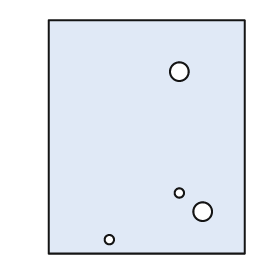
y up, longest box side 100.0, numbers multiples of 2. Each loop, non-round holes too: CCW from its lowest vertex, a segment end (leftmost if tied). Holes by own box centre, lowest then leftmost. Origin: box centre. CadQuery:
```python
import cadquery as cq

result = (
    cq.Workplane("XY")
    .moveTo(-42.0, -50.0)
    .lineTo(42.0, -50.0)
    .lineTo(42.0, 50.0)
    .lineTo(-42.0, 50.0)
    .close()
    .moveTo(-16.0, -44.0)
    .circle(2.0)
    .moveTo(24.0, -32.0)
    .circle(4.0)
    .moveTo(14.0, -24.0)
    .circle(2.0)
    .moveTo(14.0, 28.0)
    .circle(4.0)
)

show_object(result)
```